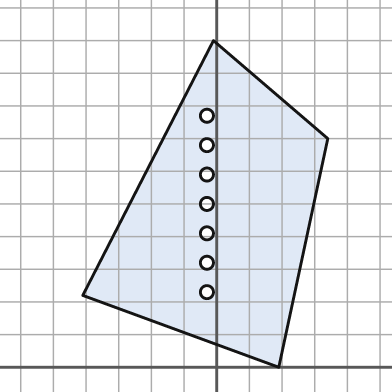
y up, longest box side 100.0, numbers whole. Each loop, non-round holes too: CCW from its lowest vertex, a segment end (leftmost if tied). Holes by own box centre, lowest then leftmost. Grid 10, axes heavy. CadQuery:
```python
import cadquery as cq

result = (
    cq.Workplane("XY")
    .moveTo(19.0, 0.0)
    .lineTo(34.0, 70.0)
    .lineTo(-1.0, 100.0)
    .lineTo(-41.0, 22.0)
    .close()
    .moveTo(-3.0, 23.0)
    .circle(2.0)
    .moveTo(-3.0, 32.0)
    .circle(2.0)
    .moveTo(-3.0, 41.0)
    .circle(2.0)
    .moveTo(-3.0, 50.0)
    .circle(2.0)
    .moveTo(-3.0, 59.0)
    .circle(2.0)
    .moveTo(-3.0, 68.0)
    .circle(2.0)
    .moveTo(-3.0, 77.0)
    .circle(2.0)
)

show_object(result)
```